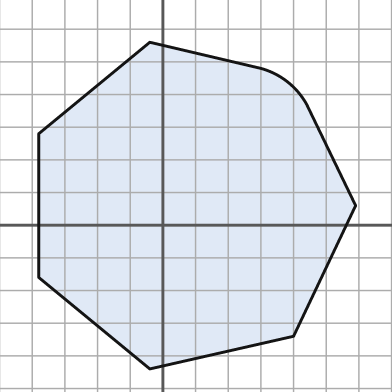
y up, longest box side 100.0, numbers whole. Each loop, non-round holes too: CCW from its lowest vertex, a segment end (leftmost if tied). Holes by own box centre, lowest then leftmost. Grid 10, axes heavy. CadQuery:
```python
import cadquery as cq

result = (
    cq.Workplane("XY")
    .moveTo(-4.0, -44.0)
    .lineTo(40.0, -34.0)
    .lineTo(59.0, 6.0)
    .lineTo(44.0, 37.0)
    .threePointArc((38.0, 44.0), (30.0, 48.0))
    .lineTo(-4.0, 56.0)
    .lineTo(-38.0, 28.0)
    .lineTo(-38.0, -16.0)
    .close()
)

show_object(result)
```